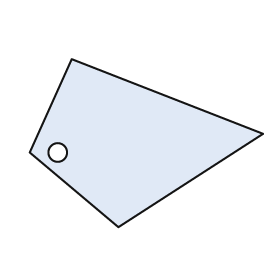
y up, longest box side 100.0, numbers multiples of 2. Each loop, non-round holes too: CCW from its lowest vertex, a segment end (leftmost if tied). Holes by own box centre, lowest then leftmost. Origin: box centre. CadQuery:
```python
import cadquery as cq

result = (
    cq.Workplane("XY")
    .moveTo(-12.0, -36.0)
    .lineTo(50.0, 4.0)
    .lineTo(-32.0, 36.0)
    .lineTo(-50.0, -4.0)
    .close()
    .moveTo(-38.0, -4.0)
    .circle(4.0)
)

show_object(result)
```